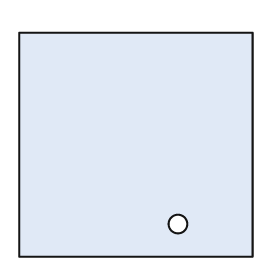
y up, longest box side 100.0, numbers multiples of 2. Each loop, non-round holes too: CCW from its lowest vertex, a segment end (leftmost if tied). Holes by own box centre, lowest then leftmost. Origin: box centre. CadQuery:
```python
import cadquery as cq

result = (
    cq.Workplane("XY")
    .moveTo(-50.0, -48.0)
    .lineTo(50.0, -48.0)
    .lineTo(50.0, 48.0)
    .lineTo(-50.0, 48.0)
    .close()
    .moveTo(18.0, -34.0)
    .circle(4.0)
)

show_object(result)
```